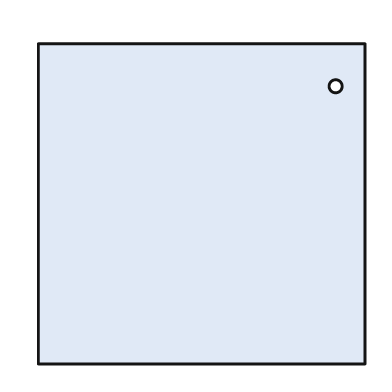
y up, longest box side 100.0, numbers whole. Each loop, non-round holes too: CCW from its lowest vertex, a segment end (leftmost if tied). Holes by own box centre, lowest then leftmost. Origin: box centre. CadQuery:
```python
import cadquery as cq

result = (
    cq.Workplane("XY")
    .moveTo(-50.0, -49.0)
    .lineTo(50.0, -49.0)
    .lineTo(50.0, 49.0)
    .lineTo(-50.0, 49.0)
    .close()
    .moveTo(41.0, 36.0)
    .circle(2.0)
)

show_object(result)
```